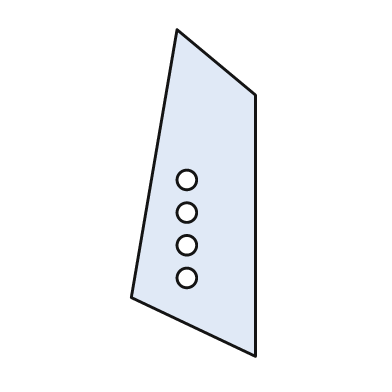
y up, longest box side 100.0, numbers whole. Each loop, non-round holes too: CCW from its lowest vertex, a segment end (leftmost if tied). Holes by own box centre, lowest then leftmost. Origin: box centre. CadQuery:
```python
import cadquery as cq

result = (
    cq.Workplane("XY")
    .moveTo(19.0, -50.0)
    .lineTo(19.0, 30.0)
    .lineTo(-5.0, 50.0)
    .lineTo(-19.0, -32.0)
    .close()
    .moveTo(-2.0, -26.0)
    .circle(3.0)
    .moveTo(-2.0, -16.0)
    .circle(3.0)
    .moveTo(-2.0, -6.0)
    .circle(3.0)
    .moveTo(-2.0, 4.0)
    .circle(3.0)
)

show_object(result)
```